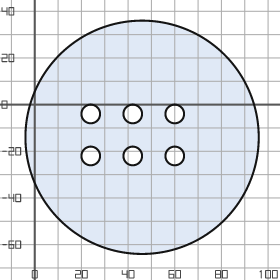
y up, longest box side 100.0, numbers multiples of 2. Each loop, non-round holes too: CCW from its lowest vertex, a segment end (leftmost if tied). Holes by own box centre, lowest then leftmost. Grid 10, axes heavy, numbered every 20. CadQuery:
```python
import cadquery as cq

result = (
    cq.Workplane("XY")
    .moveTo(46.0, -14.0)
    .circle(50.0)
    .moveTo(24.0, -22.0)
    .circle(4.0)
    .moveTo(42.0, -22.0)
    .circle(4.0)
    .moveTo(60.0, -22.0)
    .circle(4.0)
    .moveTo(24.0, -4.0)
    .circle(4.0)
    .moveTo(42.0, -4.0)
    .circle(4.0)
    .moveTo(60.0, -4.0)
    .circle(4.0)
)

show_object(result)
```